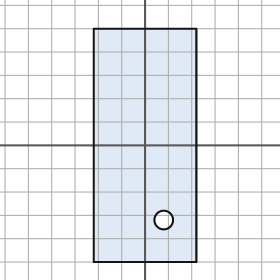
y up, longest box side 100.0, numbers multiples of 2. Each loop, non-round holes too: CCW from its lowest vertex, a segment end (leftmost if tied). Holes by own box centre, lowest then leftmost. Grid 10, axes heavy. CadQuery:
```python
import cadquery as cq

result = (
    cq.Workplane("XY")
    .moveTo(-22.0, -50.0)
    .lineTo(22.0, -50.0)
    .lineTo(22.0, 50.0)
    .lineTo(-22.0, 50.0)
    .close()
    .moveTo(8.0, -32.0)
    .circle(4.0)
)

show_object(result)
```